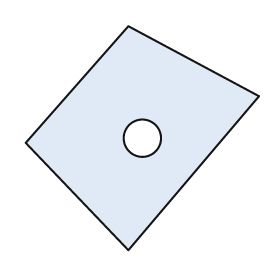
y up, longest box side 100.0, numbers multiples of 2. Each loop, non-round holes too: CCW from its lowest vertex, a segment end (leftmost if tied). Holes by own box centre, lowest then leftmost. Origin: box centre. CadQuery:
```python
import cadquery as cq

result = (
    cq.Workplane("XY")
    .moveTo(-6.0, -48.0)
    .lineTo(50.0, 18.0)
    .lineTo(-6.0, 48.0)
    .lineTo(-50.0, -2.0)
    .close()
    .moveTo(0.0, 0.0)
    .circle(8.0)
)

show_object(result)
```